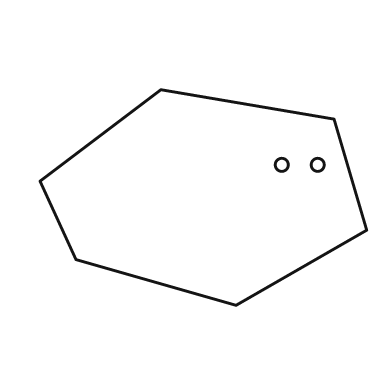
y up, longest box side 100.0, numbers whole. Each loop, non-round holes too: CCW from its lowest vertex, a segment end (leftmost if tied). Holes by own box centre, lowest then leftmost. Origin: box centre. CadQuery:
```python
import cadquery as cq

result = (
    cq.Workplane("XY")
    .moveTo(10.0, -33.0)
    .lineTo(50.0, -10.0)
    .lineTo(40.0, 24.0)
    .lineTo(-13.0, 33.0)
    .lineTo(-50.0, 5.0)
    .lineTo(-39.0, -19.0)
    .close()
    .moveTo(24.0, 10.0)
    .circle(2.0)
    .moveTo(35.0, 10.0)
    .circle(2.0)
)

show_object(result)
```